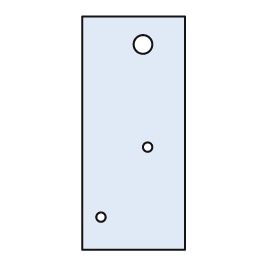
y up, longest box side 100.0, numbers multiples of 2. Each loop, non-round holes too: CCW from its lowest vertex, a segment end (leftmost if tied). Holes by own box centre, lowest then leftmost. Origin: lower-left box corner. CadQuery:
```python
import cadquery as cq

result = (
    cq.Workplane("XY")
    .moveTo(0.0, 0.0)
    .lineTo(44.0, 0.0)
    .lineTo(44.0, 100.0)
    .lineTo(0.0, 100.0)
    .close()
    .moveTo(8.0, 14.0)
    .circle(2.0)
    .moveTo(28.0, 44.0)
    .circle(2.0)
    .moveTo(26.0, 88.0)
    .circle(4.0)
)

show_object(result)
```